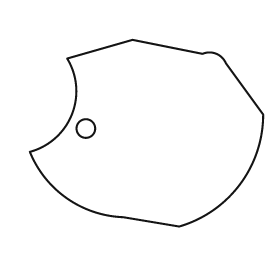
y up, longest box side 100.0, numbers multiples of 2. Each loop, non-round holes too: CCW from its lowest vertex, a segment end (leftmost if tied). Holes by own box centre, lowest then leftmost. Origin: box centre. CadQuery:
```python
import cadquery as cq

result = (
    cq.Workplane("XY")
    .moveTo(14.0, -40.0)
    .threePointArc((40.0, -22.0), (50.0, 8.0))
    .lineTo(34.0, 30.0)
    .threePointArc((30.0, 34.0), (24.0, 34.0))
    .lineTo(-6.0, 40.0)
    .lineTo(-34.0, 32.0)
    .threePointArc((-32.0, 8.0), (-50.0, -8.0))
    .threePointArc((-34.0, -28.0), (-10.0, -36.0))
    .close()
    .moveTo(-26.0, 2.0)
    .circle(4.0)
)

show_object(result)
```